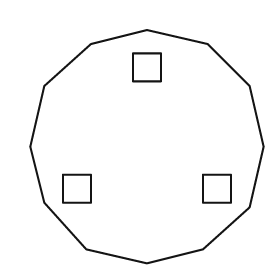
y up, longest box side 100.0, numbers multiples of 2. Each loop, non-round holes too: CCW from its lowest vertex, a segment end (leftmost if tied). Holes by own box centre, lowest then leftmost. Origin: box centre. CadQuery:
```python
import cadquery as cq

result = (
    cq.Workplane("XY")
    .moveTo(0.0, -50.0)
    .lineTo(24.0, -44.0)
    .lineTo(44.0, -26.0)
    .lineTo(50.0, 0.0)
    .lineTo(44.0, 26.0)
    .lineTo(26.0, 44.0)
    .lineTo(0.0, 50.0)
    .lineTo(-24.0, 44.0)
    .lineTo(-44.0, 26.0)
    .lineTo(-50.0, 0.0)
    .lineTo(-44.0, -24.0)
    .lineTo(-26.0, -44.0)
    .close()
    .moveTo(-36.0, -24.0)
    .lineTo(-24.0, -24.0)
    .lineTo(-24.0, -12.0)
    .lineTo(-36.0, -12.0)
    .close()
    .moveTo(24.0, -24.0)
    .lineTo(36.0, -24.0)
    .lineTo(36.0, -12.0)
    .lineTo(24.0, -12.0)
    .close()
    .moveTo(-6.0, 28.0)
    .lineTo(6.0, 28.0)
    .lineTo(6.0, 40.0)
    .lineTo(-6.0, 40.0)
    .close()
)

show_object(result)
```